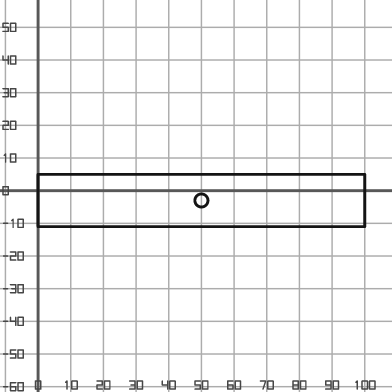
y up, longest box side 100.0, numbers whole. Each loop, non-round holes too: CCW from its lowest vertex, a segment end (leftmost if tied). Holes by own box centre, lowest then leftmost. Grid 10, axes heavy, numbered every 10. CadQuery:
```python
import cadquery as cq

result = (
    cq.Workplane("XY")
    .moveTo(0.0, -11.0)
    .lineTo(100.0, -11.0)
    .lineTo(100.0, 5.0)
    .lineTo(0.0, 5.0)
    .close()
    .moveTo(50.0, -3.0)
    .circle(2.0)
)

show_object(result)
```